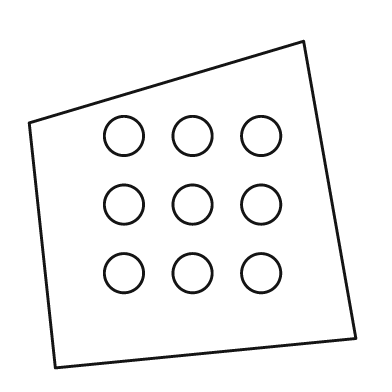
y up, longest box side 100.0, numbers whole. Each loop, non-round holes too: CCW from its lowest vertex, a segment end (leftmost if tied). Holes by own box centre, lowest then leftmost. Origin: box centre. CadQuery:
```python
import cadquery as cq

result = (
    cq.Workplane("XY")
    .moveTo(-42.0, -50.0)
    .lineTo(50.0, -41.0)
    .lineTo(34.0, 50.0)
    .lineTo(-50.0, 25.0)
    .close()
    .moveTo(-21.0, -21.0)
    .circle(6.0)
    .moveTo(0.0, -21.0)
    .circle(6.0)
    .moveTo(21.0, -21.0)
    .circle(6.0)
    .moveTo(-21.0, 0.0)
    .circle(6.0)
    .moveTo(0.0, 0.0)
    .circle(6.0)
    .moveTo(21.0, 0.0)
    .circle(6.0)
    .moveTo(-21.0, 21.0)
    .circle(6.0)
    .moveTo(0.0, 21.0)
    .circle(6.0)
    .moveTo(21.0, 21.0)
    .circle(6.0)
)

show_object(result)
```